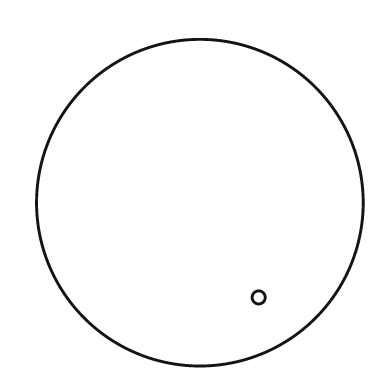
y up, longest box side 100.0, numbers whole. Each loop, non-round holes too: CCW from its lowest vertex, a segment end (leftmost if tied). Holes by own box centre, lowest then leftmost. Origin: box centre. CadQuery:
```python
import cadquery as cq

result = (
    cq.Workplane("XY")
    .moveTo(0.0, 0.0)
    .circle(50.0)
    .moveTo(18.0, -29.0)
    .circle(2.0)
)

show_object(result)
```